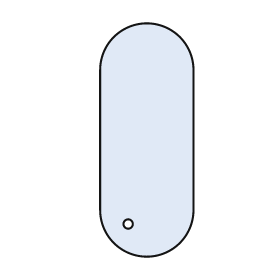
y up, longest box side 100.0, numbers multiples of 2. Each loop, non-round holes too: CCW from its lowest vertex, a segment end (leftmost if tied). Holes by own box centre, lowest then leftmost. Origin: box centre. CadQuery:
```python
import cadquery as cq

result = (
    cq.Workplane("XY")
    .moveTo(-20.0, -30.0)
    .threePointArc((0.0, -50.0), (20.0, -30.0))
    .lineTo(20.0, 30.0)
    .threePointArc((0.0, 50.0), (-20.0, 30.0))
    .close()
    .moveTo(-8.0, -36.0)
    .circle(2.0)
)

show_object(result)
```